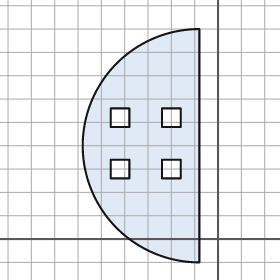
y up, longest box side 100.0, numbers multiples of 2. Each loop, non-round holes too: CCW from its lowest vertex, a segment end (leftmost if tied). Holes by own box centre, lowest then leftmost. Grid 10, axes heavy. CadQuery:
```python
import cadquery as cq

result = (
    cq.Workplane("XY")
    .moveTo(-8.0, -10.0)
    .lineTo(-8.0, 90.0)
    .threePointArc((-58.0, 40.0), (-8.0, -10.0))
    .close()
    .moveTo(-46.0, 26.0)
    .lineTo(-38.0, 26.0)
    .lineTo(-38.0, 34.0)
    .lineTo(-46.0, 34.0)
    .close()
    .moveTo(-24.0, 26.0)
    .lineTo(-16.0, 26.0)
    .lineTo(-16.0, 34.0)
    .lineTo(-24.0, 34.0)
    .close()
    .moveTo(-46.0, 48.0)
    .lineTo(-38.0, 48.0)
    .lineTo(-38.0, 56.0)
    .lineTo(-46.0, 56.0)
    .close()
    .moveTo(-24.0, 48.0)
    .lineTo(-16.0, 48.0)
    .lineTo(-16.0, 56.0)
    .lineTo(-24.0, 56.0)
    .close()
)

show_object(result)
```